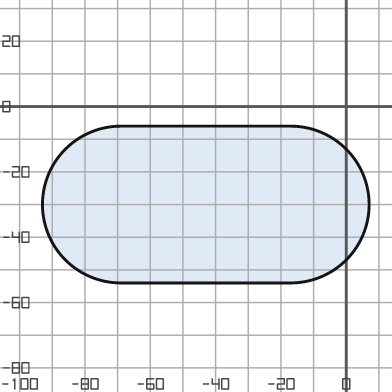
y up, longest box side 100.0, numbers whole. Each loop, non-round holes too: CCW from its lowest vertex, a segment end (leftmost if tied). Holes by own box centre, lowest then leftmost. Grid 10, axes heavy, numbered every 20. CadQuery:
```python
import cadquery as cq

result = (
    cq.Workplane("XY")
    .moveTo(-69.0, -54.0)
    .lineTo(-17.0, -54.0)
    .threePointArc((7.0, -30.0), (-17.0, -6.0))
    .lineTo(-69.0, -6.0)
    .threePointArc((-93.0, -30.0), (-69.0, -54.0))
    .close()
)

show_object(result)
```